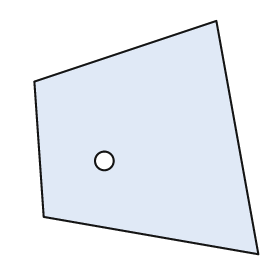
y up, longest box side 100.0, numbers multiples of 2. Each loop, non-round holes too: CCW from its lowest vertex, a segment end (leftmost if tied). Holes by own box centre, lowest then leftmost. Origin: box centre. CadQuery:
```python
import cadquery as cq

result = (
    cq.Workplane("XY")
    .moveTo(48.0, -50.0)
    .lineTo(30.0, 50.0)
    .lineTo(-48.0, 24.0)
    .lineTo(-44.0, -34.0)
    .close()
    .moveTo(-18.0, -10.0)
    .circle(4.0)
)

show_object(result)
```